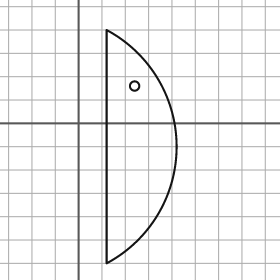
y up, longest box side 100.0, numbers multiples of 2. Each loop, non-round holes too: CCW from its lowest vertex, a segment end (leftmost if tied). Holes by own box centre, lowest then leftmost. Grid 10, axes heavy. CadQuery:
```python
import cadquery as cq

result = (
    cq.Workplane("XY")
    .moveTo(12.0, -60.0)
    .threePointArc((42.0, -10.0), (12.0, 40.0))
    .close()
    .moveTo(24.0, 16.0)
    .circle(2.0)
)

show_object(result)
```